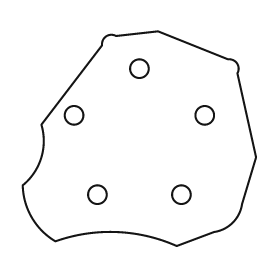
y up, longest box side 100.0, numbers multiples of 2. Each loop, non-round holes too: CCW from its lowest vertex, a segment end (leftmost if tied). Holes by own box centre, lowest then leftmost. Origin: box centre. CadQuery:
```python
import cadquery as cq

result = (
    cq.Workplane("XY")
    .moveTo(16.0, -46.0)
    .lineTo(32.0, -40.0)
    .threePointArc((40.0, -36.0), (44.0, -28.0))
    .lineTo(50.0, -8.0)
    .lineTo(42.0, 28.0)
    .threePointArc((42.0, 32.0), (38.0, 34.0))
    .lineTo(8.0, 46.0)
    .lineTo(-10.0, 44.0)
    .threePointArc((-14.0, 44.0), (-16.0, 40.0))
    .lineTo(-42.0, 6.0)
    .threePointArc((-42.0, -8.0), (-50.0, -20.0))
    .threePointArc((-46.0, -34.0), (-36.0, -44.0))
    .threePointArc((-10.0, -40.0), (16.0, -46.0))
    .close()
    .moveTo(-18.0, -24.0)
    .circle(4.0)
    .moveTo(18.0, -24.0)
    .circle(4.0)
    .moveTo(-28.0, 10.0)
    .circle(4.0)
    .moveTo(28.0, 10.0)
    .circle(4.0)
    .moveTo(0.0, 30.0)
    .circle(4.0)
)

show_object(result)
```